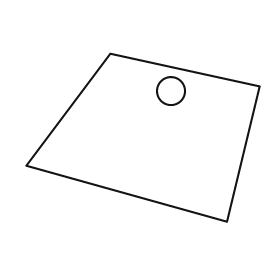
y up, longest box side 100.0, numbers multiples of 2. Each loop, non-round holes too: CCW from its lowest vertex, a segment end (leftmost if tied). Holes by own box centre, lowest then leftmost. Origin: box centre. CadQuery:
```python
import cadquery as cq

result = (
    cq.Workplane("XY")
    .moveTo(36.0, -36.0)
    .lineTo(50.0, 22.0)
    .lineTo(-14.0, 36.0)
    .lineTo(-50.0, -12.0)
    .close()
    .moveTo(12.0, 20.0)
    .circle(6.0)
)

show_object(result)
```